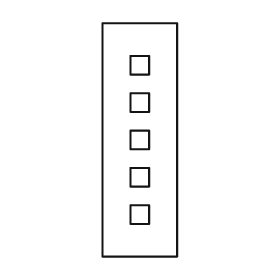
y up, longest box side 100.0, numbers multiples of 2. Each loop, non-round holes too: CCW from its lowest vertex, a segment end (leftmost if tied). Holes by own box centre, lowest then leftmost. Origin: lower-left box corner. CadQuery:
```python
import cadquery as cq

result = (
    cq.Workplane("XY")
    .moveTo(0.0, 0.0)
    .lineTo(32.0, 0.0)
    .lineTo(32.0, 100.0)
    .lineTo(0.0, 100.0)
    .close()
    .moveTo(12.0, 14.0)
    .lineTo(20.0, 14.0)
    .lineTo(20.0, 22.0)
    .lineTo(12.0, 22.0)
    .close()
    .moveTo(12.0, 30.0)
    .lineTo(20.0, 30.0)
    .lineTo(20.0, 38.0)
    .lineTo(12.0, 38.0)
    .close()
    .moveTo(12.0, 46.0)
    .lineTo(20.0, 46.0)
    .lineTo(20.0, 54.0)
    .lineTo(12.0, 54.0)
    .close()
    .moveTo(12.0, 62.0)
    .lineTo(20.0, 62.0)
    .lineTo(20.0, 70.0)
    .lineTo(12.0, 70.0)
    .close()
    .moveTo(12.0, 78.0)
    .lineTo(20.0, 78.0)
    .lineTo(20.0, 86.0)
    .lineTo(12.0, 86.0)
    .close()
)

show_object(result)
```